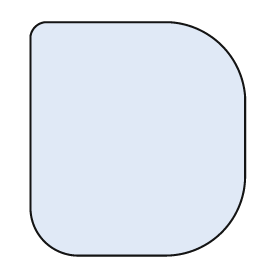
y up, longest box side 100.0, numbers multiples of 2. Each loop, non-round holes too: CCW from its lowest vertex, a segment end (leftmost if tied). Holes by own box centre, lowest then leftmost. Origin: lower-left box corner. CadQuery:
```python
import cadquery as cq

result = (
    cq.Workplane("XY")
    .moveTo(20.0, 0.0)
    .lineTo(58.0, 0.0)
    .threePointArc((82.0, 10.0), (92.0, 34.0))
    .lineTo(92.0, 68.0)
    .threePointArc((82.0, 90.0), (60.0, 100.0))
    .lineTo(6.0, 100.0)
    .threePointArc((2.0, 98.0), (0.0, 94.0))
    .lineTo(0.0, 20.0)
    .threePointArc((6.0, 6.0), (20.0, 0.0))
    .close()
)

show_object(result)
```